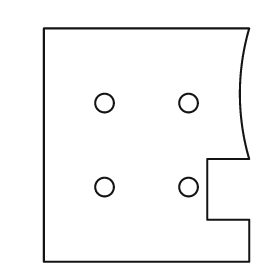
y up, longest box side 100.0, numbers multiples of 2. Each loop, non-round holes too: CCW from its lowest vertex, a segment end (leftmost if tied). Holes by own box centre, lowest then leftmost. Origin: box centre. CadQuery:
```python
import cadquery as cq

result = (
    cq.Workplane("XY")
    .moveTo(-44.0, -50.0)
    .lineTo(44.0, -50.0)
    .lineTo(44.0, -32.0)
    .lineTo(26.0, -32.0)
    .lineTo(26.0, -6.0)
    .lineTo(44.0, -6.0)
    .threePointArc((40.0, 22.0), (44.0, 50.0))
    .lineTo(-44.0, 50.0)
    .close()
    .moveTo(-18.0, -18.0)
    .circle(4.0)
    .moveTo(18.0, -18.0)
    .circle(4.0)
    .moveTo(-18.0, 18.0)
    .circle(4.0)
    .moveTo(18.0, 18.0)
    .circle(4.0)
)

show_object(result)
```